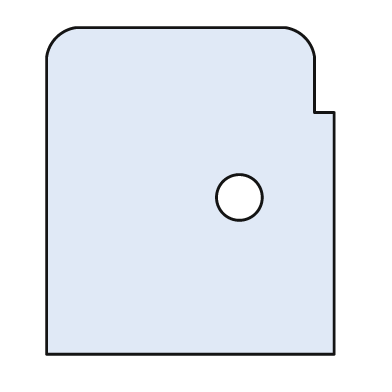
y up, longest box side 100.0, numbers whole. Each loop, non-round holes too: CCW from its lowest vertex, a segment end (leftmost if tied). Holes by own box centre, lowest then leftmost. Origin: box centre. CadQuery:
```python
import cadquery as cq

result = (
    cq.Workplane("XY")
    .moveTo(-44.0, -50.0)
    .lineTo(44.0, -50.0)
    .lineTo(44.0, 24.0)
    .lineTo(38.0, 24.0)
    .lineTo(38.0, 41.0)
    .threePointArc((35.0, 47.0), (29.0, 50.0))
    .lineTo(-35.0, 50.0)
    .threePointArc((-41.0, 47.0), (-44.0, 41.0))
    .close()
    .moveTo(15.0, -2.0)
    .circle(7.0)
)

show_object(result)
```